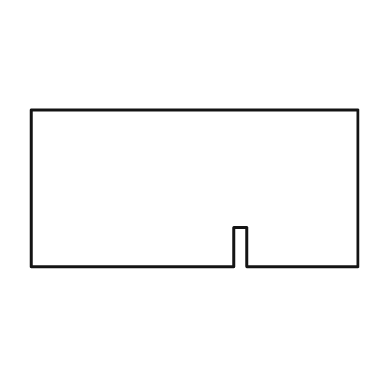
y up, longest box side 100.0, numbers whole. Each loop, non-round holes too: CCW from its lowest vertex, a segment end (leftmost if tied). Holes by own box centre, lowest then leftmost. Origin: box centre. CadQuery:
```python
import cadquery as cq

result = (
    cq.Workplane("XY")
    .moveTo(-50.0, -24.0)
    .lineTo(12.0, -24.0)
    .lineTo(12.0, -12.0)
    .lineTo(16.0, -12.0)
    .lineTo(16.0, -24.0)
    .lineTo(50.0, -24.0)
    .lineTo(50.0, 24.0)
    .lineTo(-50.0, 24.0)
    .close()
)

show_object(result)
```